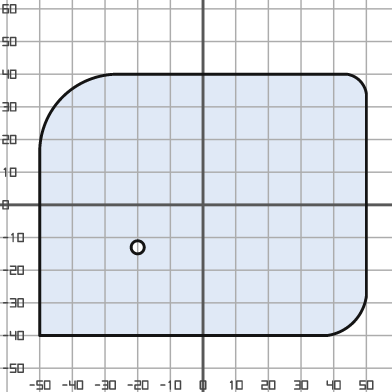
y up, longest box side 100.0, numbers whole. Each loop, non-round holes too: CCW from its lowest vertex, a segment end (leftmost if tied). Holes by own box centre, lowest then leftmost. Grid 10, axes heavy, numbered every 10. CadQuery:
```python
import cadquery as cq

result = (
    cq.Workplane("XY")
    .moveTo(-50.0, -40.0)
    .lineTo(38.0, -40.0)
    .threePointArc((46.0, -36.0), (50.0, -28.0))
    .lineTo(50.0, 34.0)
    .threePointArc((48.0, 38.0), (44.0, 40.0))
    .lineTo(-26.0, 40.0)
    .threePointArc((-43.0, 33.0), (-50.0, 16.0))
    .close()
    .moveTo(-20.0, -13.0)
    .circle(2.0)
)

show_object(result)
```